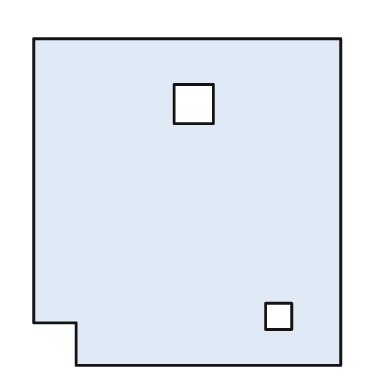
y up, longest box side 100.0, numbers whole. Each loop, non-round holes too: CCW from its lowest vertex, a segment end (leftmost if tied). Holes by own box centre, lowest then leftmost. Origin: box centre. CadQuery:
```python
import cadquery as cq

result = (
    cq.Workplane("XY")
    .moveTo(-34.0, -50.0)
    .lineTo(47.0, -50.0)
    .lineTo(47.0, 50.0)
    .lineTo(-47.0, 50.0)
    .lineTo(-47.0, -37.0)
    .lineTo(-34.0, -37.0)
    .close()
    .moveTo(24.0, -39.0)
    .lineTo(32.0, -39.0)
    .lineTo(32.0, -31.0)
    .lineTo(24.0, -31.0)
    .close()
    .moveTo(-4.0, 24.0)
    .lineTo(8.0, 24.0)
    .lineTo(8.0, 36.0)
    .lineTo(-4.0, 36.0)
    .close()
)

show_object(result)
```